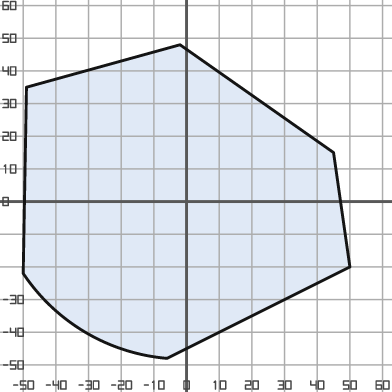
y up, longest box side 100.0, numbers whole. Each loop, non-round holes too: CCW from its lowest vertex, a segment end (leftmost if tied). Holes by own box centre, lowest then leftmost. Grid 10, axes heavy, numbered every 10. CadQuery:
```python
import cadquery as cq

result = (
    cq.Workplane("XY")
    .moveTo(-6.0, -48.0)
    .lineTo(50.0, -20.0)
    .lineTo(45.0, 15.0)
    .lineTo(-2.0, 48.0)
    .lineTo(-49.0, 35.0)
    .lineTo(-50.0, -22.0)
    .threePointArc((-31.0, -40.0), (-6.0, -48.0))
    .close()
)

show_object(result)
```